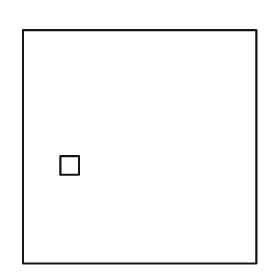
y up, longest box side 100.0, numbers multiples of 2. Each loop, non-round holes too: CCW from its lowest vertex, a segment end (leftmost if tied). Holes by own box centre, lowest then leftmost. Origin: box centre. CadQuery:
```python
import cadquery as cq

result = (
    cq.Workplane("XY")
    .moveTo(-50.0, -50.0)
    .lineTo(50.0, -50.0)
    .lineTo(50.0, 50.0)
    .lineTo(-50.0, 50.0)
    .close()
    .moveTo(-34.0, -12.0)
    .lineTo(-26.0, -12.0)
    .lineTo(-26.0, -4.0)
    .lineTo(-34.0, -4.0)
    .close()
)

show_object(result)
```